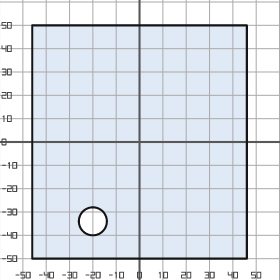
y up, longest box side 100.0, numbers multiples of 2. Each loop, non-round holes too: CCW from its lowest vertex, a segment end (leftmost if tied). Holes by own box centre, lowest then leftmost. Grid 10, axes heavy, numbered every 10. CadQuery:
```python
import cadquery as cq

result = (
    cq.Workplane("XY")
    .moveTo(-46.0, -50.0)
    .lineTo(46.0, -50.0)
    .lineTo(46.0, 50.0)
    .lineTo(-46.0, 50.0)
    .close()
    .moveTo(-20.0, -34.0)
    .circle(6.0)
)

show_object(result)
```